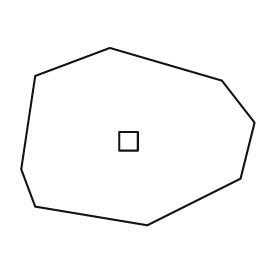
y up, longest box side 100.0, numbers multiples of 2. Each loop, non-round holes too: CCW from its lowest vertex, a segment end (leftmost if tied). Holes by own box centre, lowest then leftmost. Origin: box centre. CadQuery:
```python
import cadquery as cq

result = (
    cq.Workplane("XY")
    .moveTo(4.0, -38.0)
    .lineTo(44.0, -18.0)
    .lineTo(50.0, 6.0)
    .lineTo(36.0, 24.0)
    .lineTo(-12.0, 38.0)
    .lineTo(-44.0, 26.0)
    .lineTo(-50.0, -14.0)
    .lineTo(-44.0, -30.0)
    .close()
    .moveTo(-8.0, -6.0)
    .lineTo(0.0, -6.0)
    .lineTo(0.0, 2.0)
    .lineTo(-8.0, 2.0)
    .close()
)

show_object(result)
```